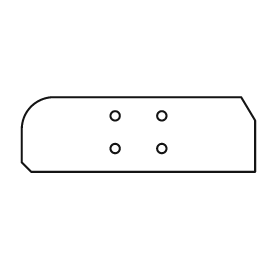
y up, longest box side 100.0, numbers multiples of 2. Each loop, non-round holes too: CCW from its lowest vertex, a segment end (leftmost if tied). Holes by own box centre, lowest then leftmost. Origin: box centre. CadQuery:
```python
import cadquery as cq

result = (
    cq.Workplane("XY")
    .moveTo(-46.0, -16.0)
    .lineTo(50.0, -16.0)
    .lineTo(50.0, 6.0)
    .lineTo(44.0, 16.0)
    .lineTo(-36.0, 16.0)
    .threePointArc((-46.0, 12.0), (-50.0, 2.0))
    .lineTo(-50.0, -12.0)
    .close()
    .moveTo(-10.0, -6.0)
    .circle(2.0)
    .moveTo(10.0, -6.0)
    .circle(2.0)
    .moveTo(-10.0, 8.0)
    .circle(2.0)
    .moveTo(10.0, 8.0)
    .circle(2.0)
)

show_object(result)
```